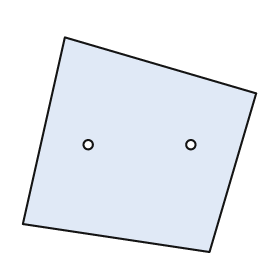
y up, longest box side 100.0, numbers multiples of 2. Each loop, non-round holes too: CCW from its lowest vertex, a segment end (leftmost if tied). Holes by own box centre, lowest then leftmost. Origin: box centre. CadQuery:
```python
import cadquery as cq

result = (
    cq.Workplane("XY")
    .moveTo(30.0, -46.0)
    .lineTo(50.0, 22.0)
    .lineTo(-32.0, 46.0)
    .lineTo(-50.0, -34.0)
    .close()
    .moveTo(-22.0, 0.0)
    .circle(2.0)
    .moveTo(22.0, 0.0)
    .circle(2.0)
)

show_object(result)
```